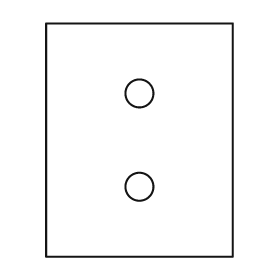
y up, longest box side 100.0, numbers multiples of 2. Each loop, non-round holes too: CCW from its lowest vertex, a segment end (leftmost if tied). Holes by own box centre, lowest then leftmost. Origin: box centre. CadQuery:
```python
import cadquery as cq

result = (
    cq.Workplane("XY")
    .moveTo(-40.0, -50.0)
    .lineTo(40.0, -50.0)
    .lineTo(40.0, 50.0)
    .lineTo(-40.0, 50.0)
    .close()
    .moveTo(0.0, -20.0)
    .circle(6.0)
    .moveTo(0.0, 20.0)
    .circle(6.0)
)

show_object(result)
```